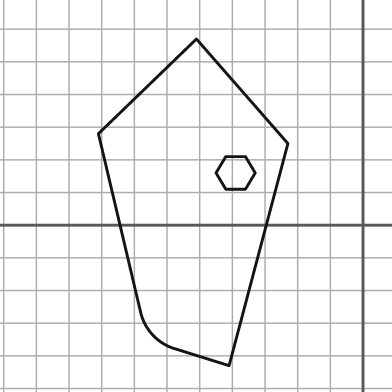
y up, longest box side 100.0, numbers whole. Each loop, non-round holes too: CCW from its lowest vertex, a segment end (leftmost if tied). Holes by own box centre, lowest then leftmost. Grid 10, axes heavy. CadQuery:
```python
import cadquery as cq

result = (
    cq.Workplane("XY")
    .moveTo(-41.0, -43.0)
    .lineTo(-23.0, 25.0)
    .lineTo(-51.0, 57.0)
    .lineTo(-81.0, 28.0)
    .lineTo(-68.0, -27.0)
    .threePointArc((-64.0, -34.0), (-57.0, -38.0))
    .close()
    .moveTo(-42.0, 11.0)
    .lineTo(-36.0, 11.0)
    .lineTo(-33.0, 16.0)
    .lineTo(-36.0, 21.0)
    .lineTo(-42.0, 21.0)
    .lineTo(-45.0, 16.0)
    .close()
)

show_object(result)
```